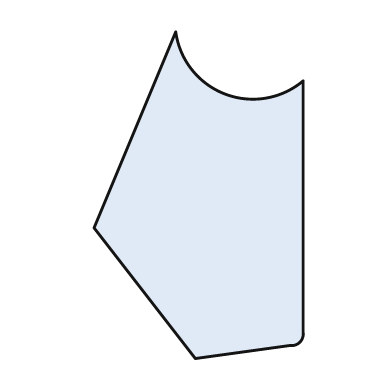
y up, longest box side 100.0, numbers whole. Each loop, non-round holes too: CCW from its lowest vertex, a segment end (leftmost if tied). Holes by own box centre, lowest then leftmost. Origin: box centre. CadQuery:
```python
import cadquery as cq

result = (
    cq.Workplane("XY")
    .moveTo(-1.0, -50.0)
    .lineTo(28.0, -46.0)
    .threePointArc((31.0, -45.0), (32.0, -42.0))
    .lineTo(32.0, 35.0)
    .threePointArc((8.0, 31.0), (-7.0, 50.0))
    .lineTo(-32.0, -10.0)
    .close()
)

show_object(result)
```